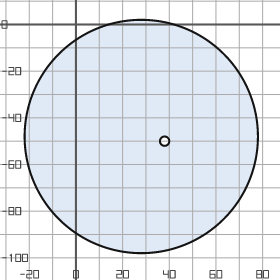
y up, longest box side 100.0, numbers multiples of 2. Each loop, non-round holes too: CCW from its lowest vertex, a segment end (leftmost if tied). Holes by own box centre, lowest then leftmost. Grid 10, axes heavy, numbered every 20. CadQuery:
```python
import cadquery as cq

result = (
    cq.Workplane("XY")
    .moveTo(28.0, -48.0)
    .circle(50.0)
    .moveTo(38.0, -50.0)
    .circle(2.0)
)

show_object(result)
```